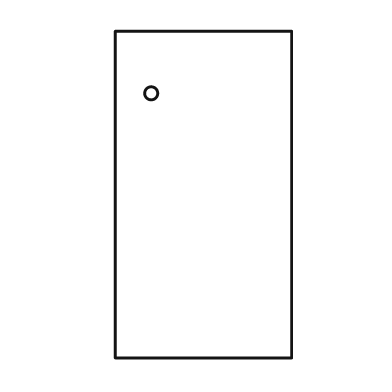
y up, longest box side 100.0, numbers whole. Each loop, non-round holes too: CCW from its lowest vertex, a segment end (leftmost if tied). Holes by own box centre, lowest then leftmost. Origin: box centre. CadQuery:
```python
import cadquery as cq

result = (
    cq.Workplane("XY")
    .moveTo(-27.0, -50.0)
    .lineTo(27.0, -50.0)
    .lineTo(27.0, 50.0)
    .lineTo(-27.0, 50.0)
    .close()
    .moveTo(-16.0, 31.0)
    .circle(2.0)
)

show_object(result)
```